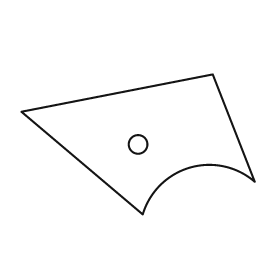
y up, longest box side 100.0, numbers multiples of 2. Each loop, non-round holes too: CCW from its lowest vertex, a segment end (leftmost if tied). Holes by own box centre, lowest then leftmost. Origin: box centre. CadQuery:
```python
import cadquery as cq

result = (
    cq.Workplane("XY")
    .moveTo(2.0, -30.0)
    .threePointArc((22.0, -10.0), (50.0, -16.0))
    .lineTo(32.0, 30.0)
    .lineTo(-50.0, 14.0)
    .close()
    .moveTo(0.0, 0.0)
    .circle(4.0)
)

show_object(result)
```